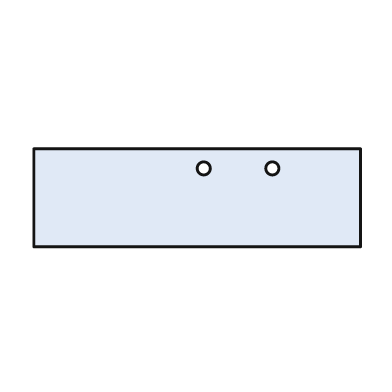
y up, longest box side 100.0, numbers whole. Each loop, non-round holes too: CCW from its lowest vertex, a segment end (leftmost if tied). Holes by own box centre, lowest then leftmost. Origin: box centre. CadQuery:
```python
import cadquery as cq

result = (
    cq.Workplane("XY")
    .moveTo(-50.0, -15.0)
    .lineTo(50.0, -15.0)
    .lineTo(50.0, 15.0)
    .lineTo(-50.0, 15.0)
    .close()
    .moveTo(2.0, 9.0)
    .circle(2.0)
    .moveTo(23.0, 9.0)
    .circle(2.0)
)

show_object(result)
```